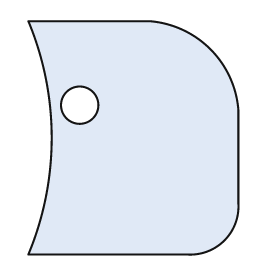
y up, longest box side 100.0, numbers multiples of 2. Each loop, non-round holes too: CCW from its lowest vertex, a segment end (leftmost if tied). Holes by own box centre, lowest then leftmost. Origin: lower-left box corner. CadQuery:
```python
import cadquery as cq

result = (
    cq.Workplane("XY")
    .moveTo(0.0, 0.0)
    .lineTo(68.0, 0.0)
    .threePointArc((84.0, 6.0), (90.0, 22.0))
    .lineTo(90.0, 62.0)
    .threePointArc((78.0, 88.0), (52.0, 100.0))
    .lineTo(0.0, 100.0)
    .threePointArc((10.0, 50.0), (0.0, 0.0))
    .close()
    .moveTo(22.0, 64.0)
    .circle(8.0)
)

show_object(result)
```